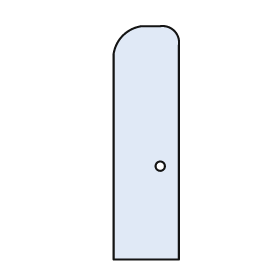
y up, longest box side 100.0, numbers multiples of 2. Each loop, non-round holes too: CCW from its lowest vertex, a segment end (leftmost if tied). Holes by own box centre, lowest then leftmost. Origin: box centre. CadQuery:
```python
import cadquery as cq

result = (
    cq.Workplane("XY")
    .moveTo(-14.0, -50.0)
    .lineTo(14.0, -50.0)
    .lineTo(14.0, 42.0)
    .threePointArc((12.0, 48.0), (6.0, 50.0))
    .lineTo(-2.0, 50.0)
    .threePointArc((-10.0, 46.0), (-14.0, 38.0))
    .close()
    .moveTo(6.0, -10.0)
    .circle(2.0)
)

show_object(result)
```